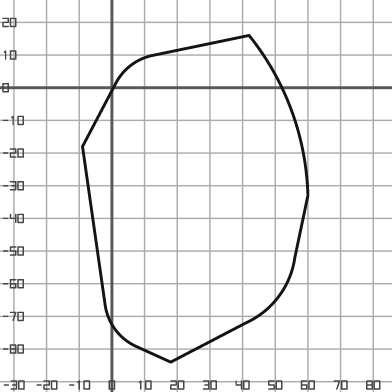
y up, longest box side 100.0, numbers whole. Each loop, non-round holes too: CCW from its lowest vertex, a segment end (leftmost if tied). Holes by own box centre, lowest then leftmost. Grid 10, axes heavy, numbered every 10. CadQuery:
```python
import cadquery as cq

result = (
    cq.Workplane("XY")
    .moveTo(18.0, -84.0)
    .lineTo(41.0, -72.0)
    .threePointArc((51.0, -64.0), (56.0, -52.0))
    .lineTo(60.0, -33.0)
    .threePointArc((55.0, -7.0), (42.0, 16.0))
    .lineTo(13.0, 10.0)
    .threePointArc((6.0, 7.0), (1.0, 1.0))
    .lineTo(-9.0, -18.0)
    .lineTo(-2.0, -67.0)
    .threePointArc((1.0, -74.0), (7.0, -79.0))
    .close()
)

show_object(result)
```